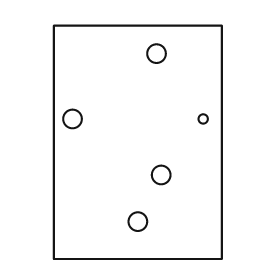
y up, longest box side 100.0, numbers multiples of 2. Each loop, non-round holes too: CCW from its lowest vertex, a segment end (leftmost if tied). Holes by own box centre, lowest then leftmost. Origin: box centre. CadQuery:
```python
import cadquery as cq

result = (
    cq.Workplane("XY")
    .moveTo(-36.0, -50.0)
    .lineTo(36.0, -50.0)
    .lineTo(36.0, 50.0)
    .lineTo(-36.0, 50.0)
    .close()
    .moveTo(0.0, -34.0)
    .circle(4.0)
    .moveTo(10.0, -14.0)
    .circle(4.0)
    .moveTo(-28.0, 10.0)
    .circle(4.0)
    .moveTo(28.0, 10.0)
    .circle(2.0)
    .moveTo(8.0, 38.0)
    .circle(4.0)
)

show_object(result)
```